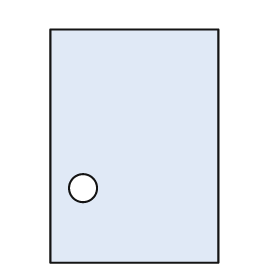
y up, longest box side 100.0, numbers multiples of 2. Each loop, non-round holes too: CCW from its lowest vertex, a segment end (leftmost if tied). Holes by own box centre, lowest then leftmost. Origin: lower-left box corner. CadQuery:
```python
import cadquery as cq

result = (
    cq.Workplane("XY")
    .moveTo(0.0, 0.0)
    .lineTo(72.0, 0.0)
    .lineTo(72.0, 100.0)
    .lineTo(0.0, 100.0)
    .close()
    .moveTo(14.0, 32.0)
    .circle(6.0)
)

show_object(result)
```